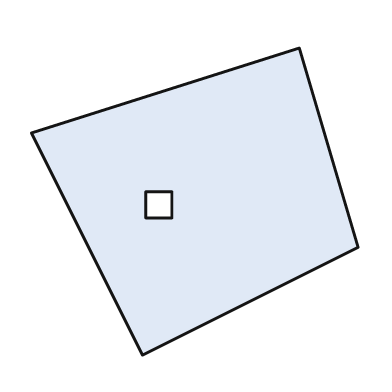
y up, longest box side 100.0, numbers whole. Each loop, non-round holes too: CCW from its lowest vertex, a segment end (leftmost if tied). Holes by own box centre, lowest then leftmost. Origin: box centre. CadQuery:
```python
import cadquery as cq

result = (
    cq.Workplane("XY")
    .moveTo(-16.0, -47.0)
    .lineTo(50.0, -14.0)
    .lineTo(32.0, 47.0)
    .lineTo(-50.0, 21.0)
    .close()
    .moveTo(-15.0, -5.0)
    .lineTo(-7.0, -5.0)
    .lineTo(-7.0, 3.0)
    .lineTo(-15.0, 3.0)
    .close()
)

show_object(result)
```